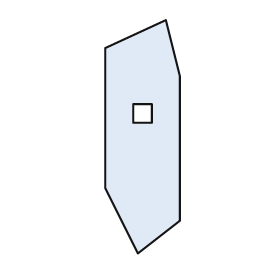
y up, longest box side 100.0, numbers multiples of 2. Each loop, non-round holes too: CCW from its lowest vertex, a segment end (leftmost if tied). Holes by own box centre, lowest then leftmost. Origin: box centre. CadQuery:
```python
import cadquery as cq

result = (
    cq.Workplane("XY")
    .moveTo(-2.0, -50.0)
    .lineTo(16.0, -36.0)
    .lineTo(16.0, 26.0)
    .lineTo(10.0, 50.0)
    .lineTo(-16.0, 38.0)
    .lineTo(-16.0, -22.0)
    .close()
    .moveTo(-4.0, 6.0)
    .lineTo(4.0, 6.0)
    .lineTo(4.0, 14.0)
    .lineTo(-4.0, 14.0)
    .close()
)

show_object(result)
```